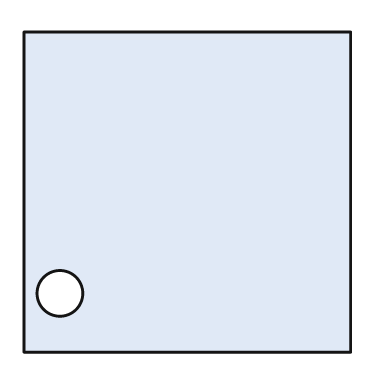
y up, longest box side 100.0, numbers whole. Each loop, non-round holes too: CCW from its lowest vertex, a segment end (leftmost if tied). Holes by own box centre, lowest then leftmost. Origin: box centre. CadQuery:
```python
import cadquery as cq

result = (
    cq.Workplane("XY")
    .moveTo(-50.0, -49.0)
    .lineTo(50.0, -49.0)
    .lineTo(50.0, 49.0)
    .lineTo(-50.0, 49.0)
    .close()
    .moveTo(-39.0, -31.0)
    .circle(7.0)
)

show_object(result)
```